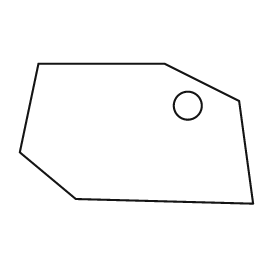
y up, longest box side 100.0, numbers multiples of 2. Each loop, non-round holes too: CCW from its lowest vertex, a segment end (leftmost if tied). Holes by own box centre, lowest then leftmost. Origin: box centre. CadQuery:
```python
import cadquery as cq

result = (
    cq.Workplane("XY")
    .moveTo(50.0, -30.0)
    .lineTo(44.0, 14.0)
    .lineTo(12.0, 30.0)
    .lineTo(-42.0, 30.0)
    .lineTo(-50.0, -8.0)
    .lineTo(-26.0, -28.0)
    .close()
    .moveTo(22.0, 12.0)
    .circle(6.0)
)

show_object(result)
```